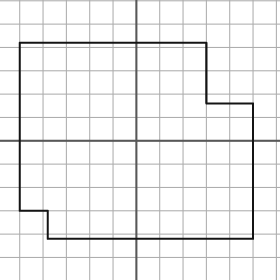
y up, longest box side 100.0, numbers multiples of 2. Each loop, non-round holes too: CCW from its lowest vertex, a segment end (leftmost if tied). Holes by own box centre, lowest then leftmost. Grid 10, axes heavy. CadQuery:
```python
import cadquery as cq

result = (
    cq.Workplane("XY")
    .moveTo(-38.0, -42.0)
    .lineTo(50.0, -42.0)
    .lineTo(50.0, 16.0)
    .lineTo(30.0, 16.0)
    .lineTo(30.0, 42.0)
    .lineTo(-50.0, 42.0)
    .lineTo(-50.0, -30.0)
    .lineTo(-38.0, -30.0)
    .close()
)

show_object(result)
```